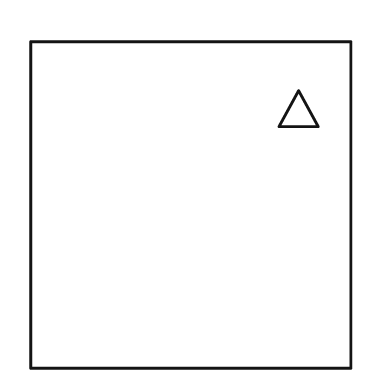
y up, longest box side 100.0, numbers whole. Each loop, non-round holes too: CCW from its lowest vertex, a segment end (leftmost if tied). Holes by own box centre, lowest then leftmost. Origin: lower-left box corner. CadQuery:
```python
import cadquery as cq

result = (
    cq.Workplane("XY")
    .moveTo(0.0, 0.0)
    .lineTo(98.0, 0.0)
    .lineTo(98.0, 100.0)
    .lineTo(0.0, 100.0)
    .close()
    .moveTo(76.0, 74.0)
    .lineTo(88.0, 74.0)
    .lineTo(82.0, 85.0)
    .close()
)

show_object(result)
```